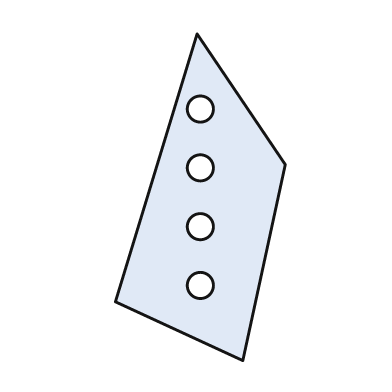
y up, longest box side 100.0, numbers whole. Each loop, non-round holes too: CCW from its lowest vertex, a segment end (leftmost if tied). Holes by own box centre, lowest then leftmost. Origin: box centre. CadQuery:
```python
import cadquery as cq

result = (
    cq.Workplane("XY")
    .moveTo(13.0, -50.0)
    .lineTo(26.0, 10.0)
    .lineTo(-1.0, 50.0)
    .lineTo(-26.0, -32.0)
    .close()
    .moveTo(0.0, -27.0)
    .circle(4.0)
    .moveTo(0.0, -9.0)
    .circle(4.0)
    .moveTo(0.0, 9.0)
    .circle(4.0)
    .moveTo(0.0, 27.0)
    .circle(4.0)
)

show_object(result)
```